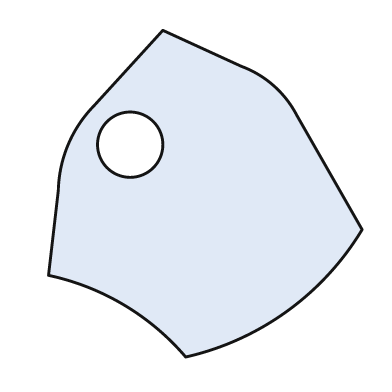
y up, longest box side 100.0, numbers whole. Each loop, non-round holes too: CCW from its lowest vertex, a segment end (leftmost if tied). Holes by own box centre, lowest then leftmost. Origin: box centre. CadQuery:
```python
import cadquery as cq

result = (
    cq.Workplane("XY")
    .moveTo(-6.0, -50.0)
    .threePointArc((25.0, -36.0), (48.0, -11.0))
    .lineTo(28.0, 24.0)
    .threePointArc((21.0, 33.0), (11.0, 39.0))
    .lineTo(-13.0, 50.0)
    .lineTo(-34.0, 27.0)
    .threePointArc((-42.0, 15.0), (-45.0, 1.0))
    .lineTo(-48.0, -25.0)
    .threePointArc((-25.0, -34.0), (-6.0, -50.0))
    .close()
    .moveTo(-23.0, 15.0)
    .circle(10.0)
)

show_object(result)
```